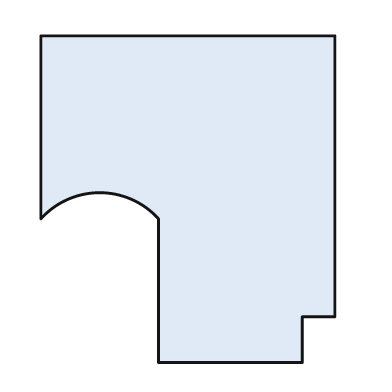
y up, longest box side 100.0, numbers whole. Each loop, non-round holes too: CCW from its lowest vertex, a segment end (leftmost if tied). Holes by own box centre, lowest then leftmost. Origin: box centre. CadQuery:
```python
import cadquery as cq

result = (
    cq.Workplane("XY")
    .moveTo(-9.0, -50.0)
    .lineTo(35.0, -50.0)
    .lineTo(35.0, -36.0)
    .lineTo(45.0, -36.0)
    .lineTo(45.0, 50.0)
    .lineTo(-45.0, 50.0)
    .lineTo(-45.0, -6.0)
    .threePointArc((-27.0, 2.0), (-9.0, -6.0))
    .close()
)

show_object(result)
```